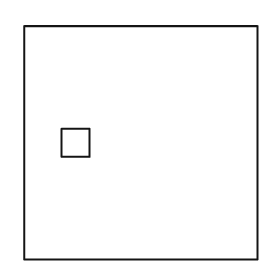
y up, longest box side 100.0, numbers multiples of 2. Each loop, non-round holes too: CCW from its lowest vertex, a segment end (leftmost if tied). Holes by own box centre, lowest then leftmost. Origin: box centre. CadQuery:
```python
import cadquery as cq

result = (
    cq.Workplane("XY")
    .moveTo(-50.0, -50.0)
    .lineTo(50.0, -50.0)
    .lineTo(50.0, 50.0)
    .lineTo(-50.0, 50.0)
    .close()
    .moveTo(-34.0, -6.0)
    .lineTo(-22.0, -6.0)
    .lineTo(-22.0, 6.0)
    .lineTo(-34.0, 6.0)
    .close()
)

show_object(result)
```